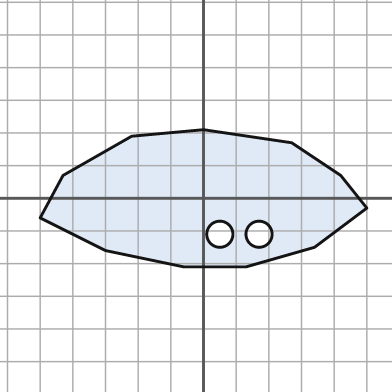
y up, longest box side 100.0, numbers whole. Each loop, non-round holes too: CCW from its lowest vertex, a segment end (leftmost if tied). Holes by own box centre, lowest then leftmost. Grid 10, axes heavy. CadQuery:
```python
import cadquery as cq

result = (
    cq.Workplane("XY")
    .moveTo(-6.0, -21.0)
    .lineTo(13.0, -21.0)
    .lineTo(34.0, -15.0)
    .lineTo(50.0, -3.0)
    .lineTo(42.0, 7.0)
    .lineTo(27.0, 17.0)
    .lineTo(0.0, 21.0)
    .lineTo(-22.0, 19.0)
    .lineTo(-43.0, 7.0)
    .lineTo(-50.0, -6.0)
    .lineTo(-30.0, -16.0)
    .close()
    .moveTo(5.0, -11.0)
    .circle(4.0)
    .moveTo(17.0, -11.0)
    .circle(4.0)
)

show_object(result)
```